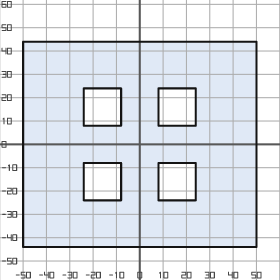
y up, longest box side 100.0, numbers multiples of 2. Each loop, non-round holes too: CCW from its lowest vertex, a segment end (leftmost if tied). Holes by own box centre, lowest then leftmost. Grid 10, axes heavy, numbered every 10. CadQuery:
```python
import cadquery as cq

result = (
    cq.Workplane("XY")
    .moveTo(-50.0, -44.0)
    .lineTo(50.0, -44.0)
    .lineTo(50.0, 44.0)
    .lineTo(-50.0, 44.0)
    .close()
    .moveTo(-24.0, -24.0)
    .lineTo(-8.0, -24.0)
    .lineTo(-8.0, -8.0)
    .lineTo(-24.0, -8.0)
    .close()
    .moveTo(8.0, -24.0)
    .lineTo(24.0, -24.0)
    .lineTo(24.0, -8.0)
    .lineTo(8.0, -8.0)
    .close()
    .moveTo(-24.0, 8.0)
    .lineTo(-8.0, 8.0)
    .lineTo(-8.0, 24.0)
    .lineTo(-24.0, 24.0)
    .close()
    .moveTo(8.0, 8.0)
    .lineTo(24.0, 8.0)
    .lineTo(24.0, 24.0)
    .lineTo(8.0, 24.0)
    .close()
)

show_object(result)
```